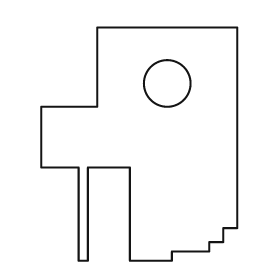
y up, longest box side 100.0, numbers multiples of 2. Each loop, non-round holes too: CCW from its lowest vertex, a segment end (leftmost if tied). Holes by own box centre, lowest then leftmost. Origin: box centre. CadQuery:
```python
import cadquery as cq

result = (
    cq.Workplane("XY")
    .moveTo(-26.0, -50.0)
    .lineTo(-22.0, -50.0)
    .lineTo(-22.0, -10.0)
    .lineTo(-4.0, -10.0)
    .lineTo(-4.0, -50.0)
    .lineTo(14.0, -50.0)
    .lineTo(14.0, -46.0)
    .lineTo(30.0, -46.0)
    .lineTo(30.0, -42.0)
    .lineTo(36.0, -42.0)
    .lineTo(36.0, -36.0)
    .lineTo(42.0, -36.0)
    .lineTo(42.0, 50.0)
    .lineTo(-18.0, 50.0)
    .lineTo(-18.0, 16.0)
    .lineTo(-42.0, 16.0)
    .lineTo(-42.0, -10.0)
    .lineTo(-26.0, -10.0)
    .close()
    .moveTo(12.0, 26.0)
    .circle(10.0)
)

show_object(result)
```